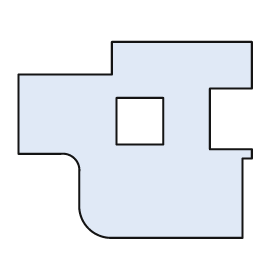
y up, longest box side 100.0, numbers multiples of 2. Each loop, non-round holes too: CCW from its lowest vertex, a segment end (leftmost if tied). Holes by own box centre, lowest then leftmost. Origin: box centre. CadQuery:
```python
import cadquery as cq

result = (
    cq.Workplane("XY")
    .moveTo(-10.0, -42.0)
    .lineTo(46.0, -42.0)
    .lineTo(46.0, -8.0)
    .lineTo(50.0, -8.0)
    .lineTo(50.0, -4.0)
    .lineTo(32.0, -4.0)
    .lineTo(32.0, 22.0)
    .lineTo(50.0, 22.0)
    .lineTo(50.0, 42.0)
    .lineTo(-10.0, 42.0)
    .lineTo(-10.0, 28.0)
    .lineTo(-50.0, 28.0)
    .lineTo(-50.0, -6.0)
    .lineTo(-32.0, -6.0)
    .threePointArc((-26.0, -8.0), (-24.0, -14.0))
    .lineTo(-24.0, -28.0)
    .threePointArc((-20.0, -38.0), (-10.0, -42.0))
    .close()
    .moveTo(-8.0, -2.0)
    .lineTo(12.0, -2.0)
    .lineTo(12.0, 18.0)
    .lineTo(-8.0, 18.0)
    .close()
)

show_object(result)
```